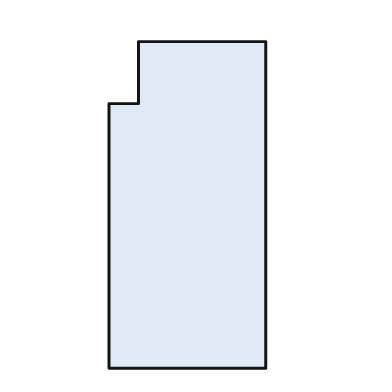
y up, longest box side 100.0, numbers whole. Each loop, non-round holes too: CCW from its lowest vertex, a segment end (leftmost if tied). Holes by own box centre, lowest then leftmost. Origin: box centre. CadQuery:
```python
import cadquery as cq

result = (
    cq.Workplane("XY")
    .moveTo(-24.0, -50.0)
    .lineTo(24.0, -50.0)
    .lineTo(24.0, 50.0)
    .lineTo(-15.0, 50.0)
    .lineTo(-15.0, 31.0)
    .lineTo(-24.0, 31.0)
    .close()
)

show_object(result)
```